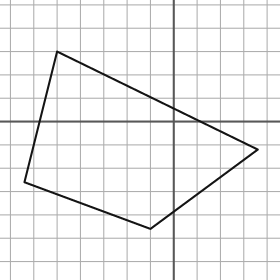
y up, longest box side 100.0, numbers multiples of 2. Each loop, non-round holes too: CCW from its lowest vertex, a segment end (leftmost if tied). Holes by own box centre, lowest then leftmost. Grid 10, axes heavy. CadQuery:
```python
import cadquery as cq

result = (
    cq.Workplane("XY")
    .moveTo(-10.0, -46.0)
    .lineTo(36.0, -12.0)
    .lineTo(-50.0, 30.0)
    .lineTo(-64.0, -26.0)
    .close()
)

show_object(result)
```